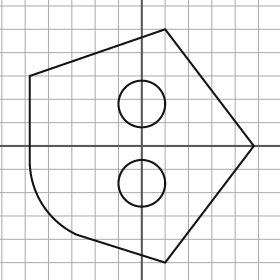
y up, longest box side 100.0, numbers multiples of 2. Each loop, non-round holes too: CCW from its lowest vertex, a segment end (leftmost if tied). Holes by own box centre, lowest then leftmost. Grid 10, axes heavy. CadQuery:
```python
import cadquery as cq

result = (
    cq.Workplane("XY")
    .moveTo(10.0, -50.0)
    .lineTo(48.0, 0.0)
    .lineTo(10.0, 50.0)
    .lineTo(-48.0, 30.0)
    .lineTo(-48.0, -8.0)
    .threePointArc((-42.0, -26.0), (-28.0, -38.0))
    .close()
    .moveTo(0.0, -16.0)
    .circle(10.0)
    .moveTo(0.0, 18.0)
    .circle(10.0)
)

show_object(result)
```